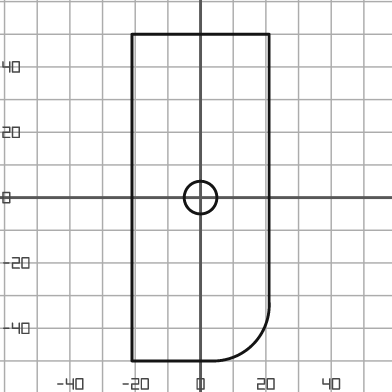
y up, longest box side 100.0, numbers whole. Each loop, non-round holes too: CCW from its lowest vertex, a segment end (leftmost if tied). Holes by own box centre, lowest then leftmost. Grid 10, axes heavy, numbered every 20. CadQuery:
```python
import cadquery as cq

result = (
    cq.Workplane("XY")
    .moveTo(-21.0, -50.0)
    .lineTo(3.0, -50.0)
    .threePointArc((16.0, -45.0), (21.0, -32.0))
    .lineTo(21.0, 50.0)
    .lineTo(-21.0, 50.0)
    .close()
    .moveTo(0.0, 0.0)
    .circle(5.0)
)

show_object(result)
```